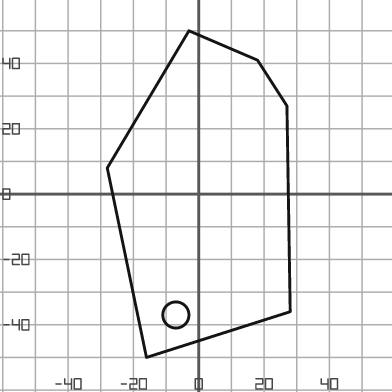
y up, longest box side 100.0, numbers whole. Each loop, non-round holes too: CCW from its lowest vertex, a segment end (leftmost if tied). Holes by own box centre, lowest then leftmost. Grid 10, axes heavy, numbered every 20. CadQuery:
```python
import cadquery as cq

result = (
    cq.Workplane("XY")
    .moveTo(-16.0, -50.0)
    .lineTo(28.0, -36.0)
    .lineTo(27.0, 27.0)
    .lineTo(18.0, 41.0)
    .lineTo(-3.0, 50.0)
    .lineTo(-28.0, 8.0)
    .close()
    .moveTo(-7.0, -37.0)
    .circle(4.0)
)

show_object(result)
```